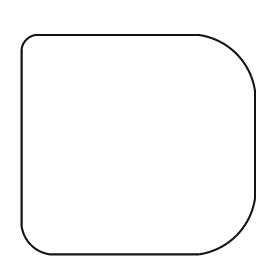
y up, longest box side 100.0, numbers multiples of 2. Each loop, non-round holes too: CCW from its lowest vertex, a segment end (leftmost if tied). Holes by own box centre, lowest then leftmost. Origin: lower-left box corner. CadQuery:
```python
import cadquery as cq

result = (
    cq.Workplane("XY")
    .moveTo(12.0, 0.0)
    .lineTo(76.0, 0.0)
    .threePointArc((92.0, 8.0), (100.0, 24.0))
    .lineTo(100.0, 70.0)
    .threePointArc((92.0, 86.0), (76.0, 94.0))
    .lineTo(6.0, 94.0)
    .threePointArc((2.0, 92.0), (0.0, 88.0))
    .lineTo(0.0, 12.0)
    .threePointArc((4.0, 4.0), (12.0, 0.0))
    .close()
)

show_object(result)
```